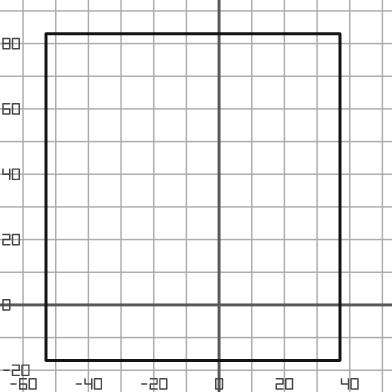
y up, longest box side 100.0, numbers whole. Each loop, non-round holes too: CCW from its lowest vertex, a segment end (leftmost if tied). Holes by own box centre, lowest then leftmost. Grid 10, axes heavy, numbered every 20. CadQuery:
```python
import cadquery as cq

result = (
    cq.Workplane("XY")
    .moveTo(-53.0, -17.0)
    .lineTo(37.0, -17.0)
    .lineTo(37.0, 83.0)
    .lineTo(-53.0, 83.0)
    .close()
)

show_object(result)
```